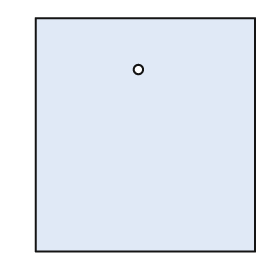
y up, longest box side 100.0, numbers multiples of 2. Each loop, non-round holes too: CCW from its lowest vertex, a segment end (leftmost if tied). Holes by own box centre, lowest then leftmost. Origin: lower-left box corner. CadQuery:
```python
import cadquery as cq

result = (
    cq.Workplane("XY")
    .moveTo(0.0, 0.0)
    .lineTo(94.0, 0.0)
    .lineTo(94.0, 100.0)
    .lineTo(0.0, 100.0)
    .close()
    .moveTo(44.0, 78.0)
    .circle(2.0)
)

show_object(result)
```